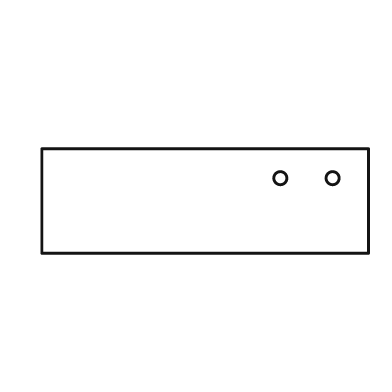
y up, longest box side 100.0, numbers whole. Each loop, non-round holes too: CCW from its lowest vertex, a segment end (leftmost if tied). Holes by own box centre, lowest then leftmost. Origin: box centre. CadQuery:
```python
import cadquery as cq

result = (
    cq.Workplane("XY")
    .moveTo(-50.0, -16.0)
    .lineTo(50.0, -16.0)
    .lineTo(50.0, 16.0)
    .lineTo(-50.0, 16.0)
    .close()
    .moveTo(23.0, 7.0)
    .circle(2.0)
    .moveTo(39.0, 7.0)
    .circle(2.0)
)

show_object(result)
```